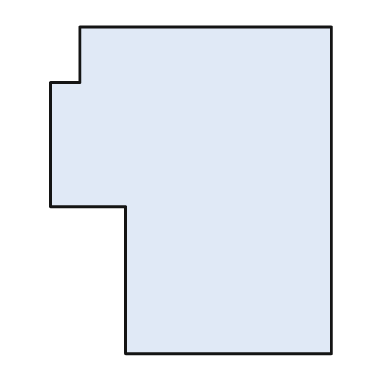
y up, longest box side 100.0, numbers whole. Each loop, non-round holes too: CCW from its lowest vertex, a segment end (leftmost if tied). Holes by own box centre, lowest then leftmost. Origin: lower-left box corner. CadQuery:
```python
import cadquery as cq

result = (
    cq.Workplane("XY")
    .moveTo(23.0, 0.0)
    .lineTo(86.0, 0.0)
    .lineTo(86.0, 100.0)
    .lineTo(9.0, 100.0)
    .lineTo(9.0, 83.0)
    .lineTo(0.0, 83.0)
    .lineTo(0.0, 45.0)
    .lineTo(23.0, 45.0)
    .close()
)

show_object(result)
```